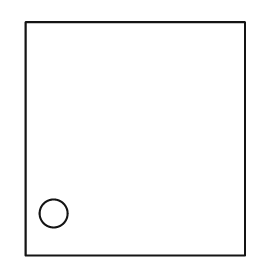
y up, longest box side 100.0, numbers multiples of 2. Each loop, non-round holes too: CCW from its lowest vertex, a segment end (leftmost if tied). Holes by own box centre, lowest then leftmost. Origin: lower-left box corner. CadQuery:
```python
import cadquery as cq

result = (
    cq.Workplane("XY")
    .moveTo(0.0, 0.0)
    .lineTo(94.0, 0.0)
    .lineTo(94.0, 100.0)
    .lineTo(0.0, 100.0)
    .close()
    .moveTo(12.0, 18.0)
    .circle(6.0)
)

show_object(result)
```